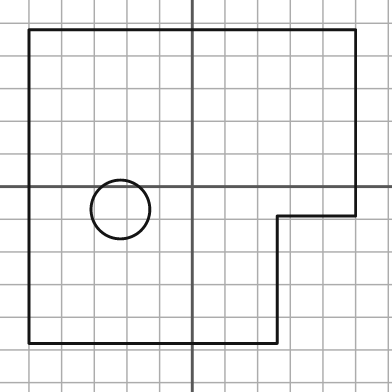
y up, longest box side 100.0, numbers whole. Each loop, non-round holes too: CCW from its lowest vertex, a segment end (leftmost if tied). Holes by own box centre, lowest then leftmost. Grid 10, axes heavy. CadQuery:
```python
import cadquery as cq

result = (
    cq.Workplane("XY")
    .moveTo(-50.0, -48.0)
    .lineTo(26.0, -48.0)
    .lineTo(26.0, -9.0)
    .lineTo(50.0, -9.0)
    .lineTo(50.0, 48.0)
    .lineTo(-50.0, 48.0)
    .close()
    .moveTo(-22.0, -7.0)
    .circle(9.0)
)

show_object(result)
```